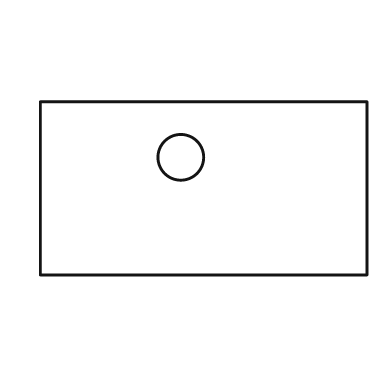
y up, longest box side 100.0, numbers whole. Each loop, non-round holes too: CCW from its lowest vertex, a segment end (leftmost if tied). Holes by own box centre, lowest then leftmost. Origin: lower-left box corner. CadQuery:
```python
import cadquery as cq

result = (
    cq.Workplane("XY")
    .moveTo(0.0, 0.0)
    .lineTo(100.0, 0.0)
    .lineTo(100.0, 53.0)
    .lineTo(0.0, 53.0)
    .close()
    .moveTo(43.0, 36.0)
    .circle(7.0)
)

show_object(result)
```